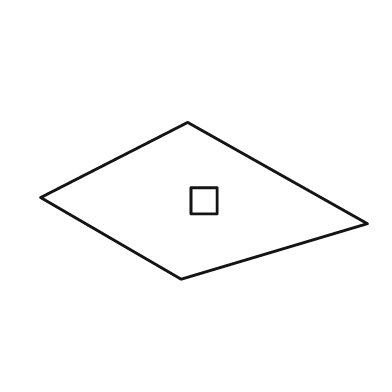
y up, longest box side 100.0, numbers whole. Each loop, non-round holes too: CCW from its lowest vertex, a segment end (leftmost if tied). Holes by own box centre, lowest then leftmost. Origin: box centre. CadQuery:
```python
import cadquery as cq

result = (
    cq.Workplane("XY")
    .moveTo(-7.0, -24.0)
    .lineTo(50.0, -7.0)
    .lineTo(-5.0, 24.0)
    .lineTo(-50.0, 1.0)
    .close()
    .moveTo(-4.0, -4.0)
    .lineTo(4.0, -4.0)
    .lineTo(4.0, 4.0)
    .lineTo(-4.0, 4.0)
    .close()
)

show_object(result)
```